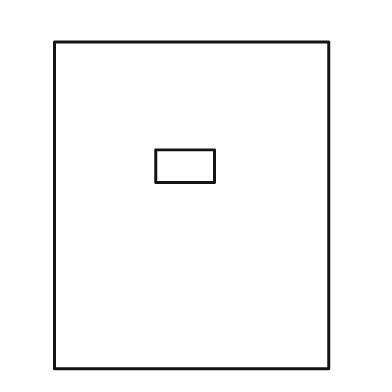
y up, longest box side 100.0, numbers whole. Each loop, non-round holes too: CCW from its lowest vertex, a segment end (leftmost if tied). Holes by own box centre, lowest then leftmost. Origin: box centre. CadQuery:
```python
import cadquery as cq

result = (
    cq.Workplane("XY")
    .moveTo(-42.0, -50.0)
    .lineTo(42.0, -50.0)
    .lineTo(42.0, 50.0)
    .lineTo(-42.0, 50.0)
    .close()
    .moveTo(-11.0, 7.0)
    .lineTo(7.0, 7.0)
    .lineTo(7.0, 17.0)
    .lineTo(-11.0, 17.0)
    .close()
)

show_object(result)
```